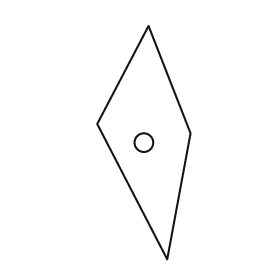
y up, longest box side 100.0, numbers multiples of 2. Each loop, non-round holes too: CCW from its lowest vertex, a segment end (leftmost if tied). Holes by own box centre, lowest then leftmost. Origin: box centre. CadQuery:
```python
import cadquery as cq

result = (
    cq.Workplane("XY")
    .moveTo(10.0, -50.0)
    .lineTo(20.0, 4.0)
    .lineTo(2.0, 50.0)
    .lineTo(-20.0, 8.0)
    .close()
    .moveTo(0.0, 0.0)
    .circle(4.0)
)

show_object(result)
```